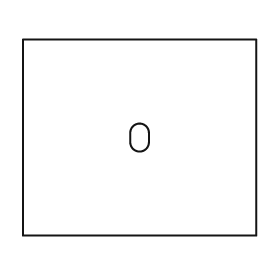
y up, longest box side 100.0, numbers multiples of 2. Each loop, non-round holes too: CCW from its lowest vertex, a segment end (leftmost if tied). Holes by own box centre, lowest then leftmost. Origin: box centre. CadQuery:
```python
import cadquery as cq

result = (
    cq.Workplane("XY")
    .moveTo(-50.0, -42.0)
    .lineTo(50.0, -42.0)
    .lineTo(50.0, 42.0)
    .lineTo(-50.0, 42.0)
    .close()
    .moveTo(-4.0, -2.0)
    .threePointArc((0.0, -6.0), (4.0, -2.0))
    .lineTo(4.0, 2.0)
    .threePointArc((0.0, 6.0), (-4.0, 2.0))
    .close()
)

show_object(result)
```